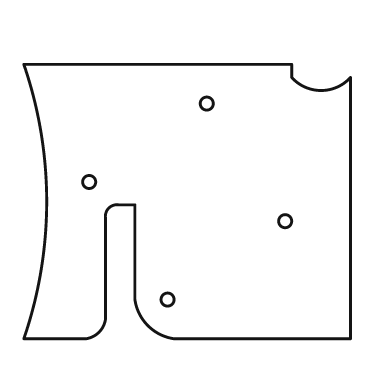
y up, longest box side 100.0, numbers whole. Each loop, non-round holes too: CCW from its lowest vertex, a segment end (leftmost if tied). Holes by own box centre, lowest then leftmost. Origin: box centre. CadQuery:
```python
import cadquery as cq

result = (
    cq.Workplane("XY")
    .moveTo(-50.0, -42.0)
    .lineTo(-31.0, -42.0)
    .threePointArc((-27.0, -40.0), (-25.0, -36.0))
    .lineTo(-25.0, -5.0)
    .threePointArc((-24.0, -2.0), (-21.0, -1.0))
    .lineTo(-16.0, -1.0)
    .lineTo(-16.0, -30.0)
    .threePointArc((-12.0, -38.0), (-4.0, -42.0))
    .lineTo(50.0, -42.0)
    .lineTo(50.0, 38.0)
    .threePointArc((41.0, 34.0), (32.0, 38.0))
    .lineTo(32.0, 42.0)
    .lineTo(-50.0, 42.0)
    .threePointArc((-43.0, 0.0), (-50.0, -42.0))
    .close()
    .moveTo(-6.0, -30.0)
    .circle(2.0)
    .moveTo(30.0, -6.0)
    .circle(2.0)
    .moveTo(-30.0, 6.0)
    .circle(2.0)
    .moveTo(6.0, 30.0)
    .circle(2.0)
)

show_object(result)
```